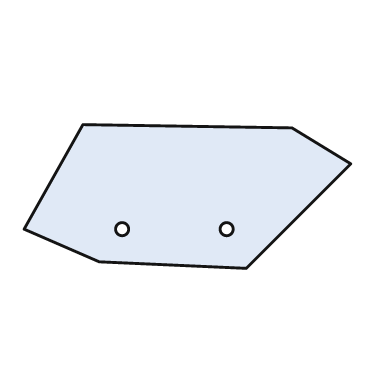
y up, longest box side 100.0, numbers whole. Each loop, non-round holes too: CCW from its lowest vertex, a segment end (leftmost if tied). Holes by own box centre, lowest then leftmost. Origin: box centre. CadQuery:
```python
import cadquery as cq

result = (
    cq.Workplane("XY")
    .moveTo(18.0, -22.0)
    .lineTo(50.0, 10.0)
    .lineTo(32.0, 21.0)
    .lineTo(-32.0, 22.0)
    .lineTo(-50.0, -10.0)
    .lineTo(-27.0, -20.0)
    .close()
    .moveTo(-20.0, -10.0)
    .circle(2.0)
    .moveTo(12.0, -10.0)
    .circle(2.0)
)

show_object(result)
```